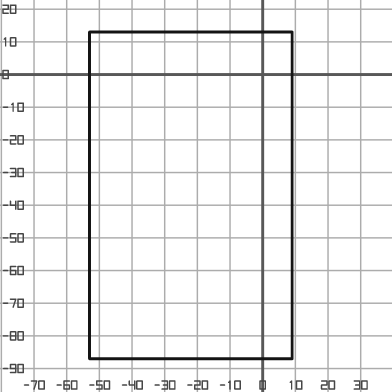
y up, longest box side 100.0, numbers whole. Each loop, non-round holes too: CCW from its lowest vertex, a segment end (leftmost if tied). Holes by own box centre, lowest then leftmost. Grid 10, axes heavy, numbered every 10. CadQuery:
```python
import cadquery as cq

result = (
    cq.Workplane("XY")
    .moveTo(-53.0, -87.0)
    .lineTo(9.0, -87.0)
    .lineTo(9.0, 13.0)
    .lineTo(-53.0, 13.0)
    .close()
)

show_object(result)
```